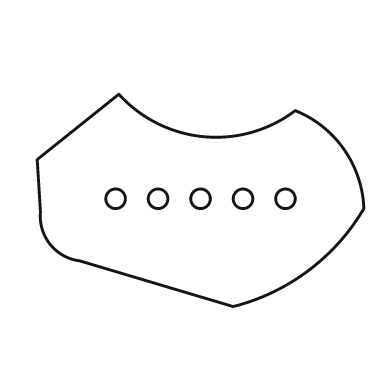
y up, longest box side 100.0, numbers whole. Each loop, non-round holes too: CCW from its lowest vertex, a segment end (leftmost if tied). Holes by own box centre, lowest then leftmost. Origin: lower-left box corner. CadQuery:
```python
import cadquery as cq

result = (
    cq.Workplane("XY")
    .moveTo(60.0, 0.0)
    .threePointArc((83.0, 11.0), (100.0, 30.0))
    .threePointArc((94.0, 48.0), (79.0, 60.0))
    .threePointArc((51.0, 52.0), (25.0, 65.0))
    .lineTo(0.0, 45.0)
    .lineTo(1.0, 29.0)
    .threePointArc((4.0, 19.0), (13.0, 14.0))
    .close()
    .moveTo(24.0, 33.0)
    .circle(3.0)
    .moveTo(37.0, 33.0)
    .circle(3.0)
    .moveTo(50.0, 33.0)
    .circle(3.0)
    .moveTo(63.0, 33.0)
    .circle(3.0)
    .moveTo(76.0, 33.0)
    .circle(3.0)
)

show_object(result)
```